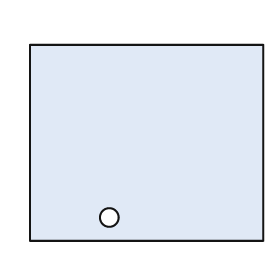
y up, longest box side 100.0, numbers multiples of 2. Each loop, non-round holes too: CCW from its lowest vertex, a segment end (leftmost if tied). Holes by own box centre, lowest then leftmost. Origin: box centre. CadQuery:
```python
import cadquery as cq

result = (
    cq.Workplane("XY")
    .moveTo(-50.0, -42.0)
    .lineTo(50.0, -42.0)
    .lineTo(50.0, 42.0)
    .lineTo(-50.0, 42.0)
    .close()
    .moveTo(-16.0, -32.0)
    .circle(4.0)
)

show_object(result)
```